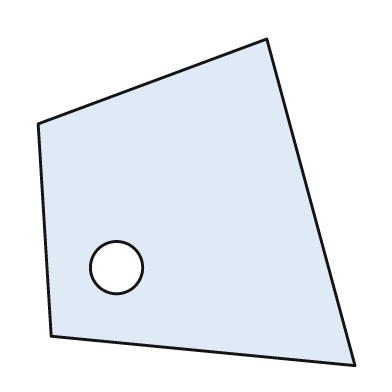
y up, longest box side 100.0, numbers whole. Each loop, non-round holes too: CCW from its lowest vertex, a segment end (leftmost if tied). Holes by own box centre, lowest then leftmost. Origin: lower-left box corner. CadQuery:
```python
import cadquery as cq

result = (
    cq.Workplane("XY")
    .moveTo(97.0, 0.0)
    .lineTo(70.0, 100.0)
    .lineTo(0.0, 74.0)
    .lineTo(4.0, 9.0)
    .close()
    .moveTo(24.0, 30.0)
    .circle(8.0)
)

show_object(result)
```